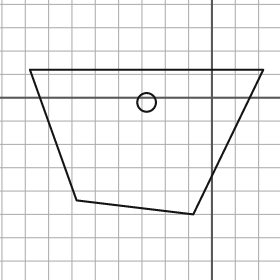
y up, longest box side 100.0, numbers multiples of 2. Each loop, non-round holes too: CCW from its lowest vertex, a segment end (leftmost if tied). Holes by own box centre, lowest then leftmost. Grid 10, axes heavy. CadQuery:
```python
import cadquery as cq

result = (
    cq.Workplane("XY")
    .moveTo(-8.0, -50.0)
    .lineTo(22.0, 12.0)
    .lineTo(-78.0, 12.0)
    .lineTo(-58.0, -44.0)
    .close()
    .moveTo(-28.0, -2.0)
    .circle(4.0)
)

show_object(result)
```